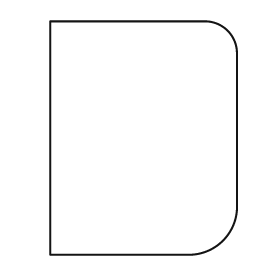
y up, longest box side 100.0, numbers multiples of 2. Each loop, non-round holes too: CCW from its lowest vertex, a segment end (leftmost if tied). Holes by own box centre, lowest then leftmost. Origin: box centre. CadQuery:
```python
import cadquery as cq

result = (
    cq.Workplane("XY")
    .moveTo(-40.0, -50.0)
    .lineTo(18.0, -50.0)
    .threePointArc((34.0, -44.0), (40.0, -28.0))
    .lineTo(40.0, 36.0)
    .threePointArc((36.0, 46.0), (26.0, 50.0))
    .lineTo(-40.0, 50.0)
    .close()
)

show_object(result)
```